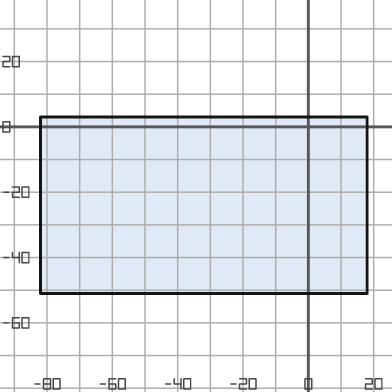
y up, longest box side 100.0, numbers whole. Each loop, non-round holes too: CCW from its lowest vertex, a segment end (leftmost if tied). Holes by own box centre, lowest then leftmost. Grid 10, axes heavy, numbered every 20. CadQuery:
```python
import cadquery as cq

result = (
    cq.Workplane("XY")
    .moveTo(-82.0, -51.0)
    .lineTo(18.0, -51.0)
    .lineTo(18.0, 3.0)
    .lineTo(-82.0, 3.0)
    .close()
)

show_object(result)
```